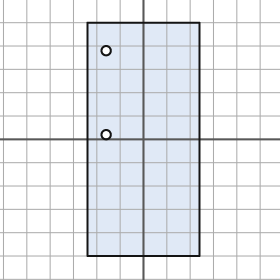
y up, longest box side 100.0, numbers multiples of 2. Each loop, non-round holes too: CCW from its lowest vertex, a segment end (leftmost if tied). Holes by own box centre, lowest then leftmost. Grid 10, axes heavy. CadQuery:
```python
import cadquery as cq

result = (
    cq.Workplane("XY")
    .moveTo(-24.0, -50.0)
    .lineTo(24.0, -50.0)
    .lineTo(24.0, 50.0)
    .lineTo(-24.0, 50.0)
    .close()
    .moveTo(-16.0, 2.0)
    .circle(2.0)
    .moveTo(-16.0, 38.0)
    .circle(2.0)
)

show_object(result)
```